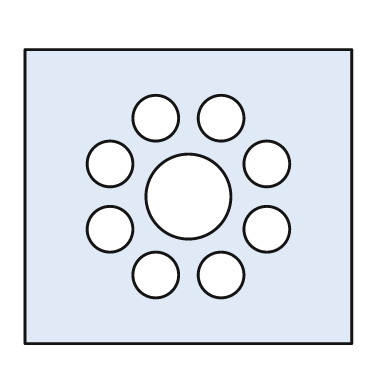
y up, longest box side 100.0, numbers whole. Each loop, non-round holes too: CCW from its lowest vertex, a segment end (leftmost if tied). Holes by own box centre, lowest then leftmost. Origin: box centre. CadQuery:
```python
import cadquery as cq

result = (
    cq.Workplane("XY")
    .moveTo(-50.0, -45.0)
    .lineTo(50.0, -45.0)
    .lineTo(50.0, 45.0)
    .lineTo(-50.0, 45.0)
    .close()
    .moveTo(-10.0, -24.0)
    .circle(7.0)
    .moveTo(10.0, -24.0)
    .circle(7.0)
    .moveTo(-24.0, -10.0)
    .circle(7.0)
    .moveTo(24.0, -10.0)
    .circle(7.0)
    .moveTo(0.0, 0.0)
    .circle(13.0)
    .moveTo(-24.0, 10.0)
    .circle(7.0)
    .moveTo(24.0, 10.0)
    .circle(7.0)
    .moveTo(-10.0, 24.0)
    .circle(7.0)
    .moveTo(10.0, 24.0)
    .circle(7.0)
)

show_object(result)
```